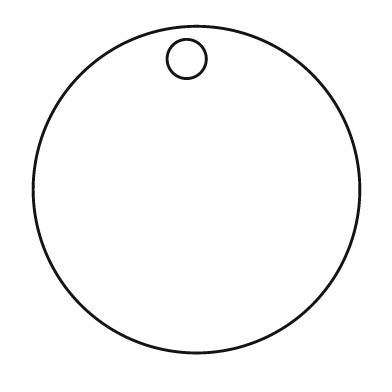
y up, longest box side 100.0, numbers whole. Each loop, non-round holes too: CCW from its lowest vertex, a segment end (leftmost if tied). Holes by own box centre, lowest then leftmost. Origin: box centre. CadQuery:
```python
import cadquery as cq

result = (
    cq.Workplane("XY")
    .moveTo(0.0, 0.0)
    .circle(50.0)
    .moveTo(-3.0, 40.0)
    .circle(6.0)
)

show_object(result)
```